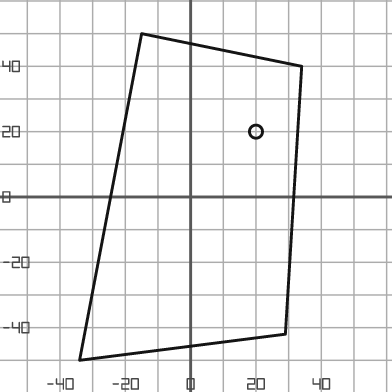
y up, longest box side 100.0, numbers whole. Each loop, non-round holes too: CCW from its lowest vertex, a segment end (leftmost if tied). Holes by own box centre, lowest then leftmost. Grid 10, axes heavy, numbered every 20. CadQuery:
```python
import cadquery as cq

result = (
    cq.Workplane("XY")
    .moveTo(-34.0, -50.0)
    .lineTo(29.0, -42.0)
    .lineTo(34.0, 40.0)
    .lineTo(-15.0, 50.0)
    .close()
    .moveTo(20.0, 20.0)
    .circle(2.0)
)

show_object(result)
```